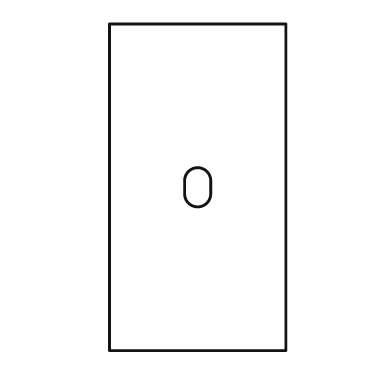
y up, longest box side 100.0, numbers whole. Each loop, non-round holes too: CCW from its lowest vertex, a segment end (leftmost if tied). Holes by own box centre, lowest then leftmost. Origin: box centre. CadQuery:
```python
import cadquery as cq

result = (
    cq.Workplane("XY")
    .moveTo(-27.0, -50.0)
    .lineTo(27.0, -50.0)
    .lineTo(27.0, 50.0)
    .lineTo(-27.0, 50.0)
    .close()
    .moveTo(-4.0, -2.0)
    .threePointArc((0.0, -6.0), (4.0, -2.0))
    .lineTo(4.0, 2.0)
    .threePointArc((0.0, 6.0), (-4.0, 2.0))
    .close()
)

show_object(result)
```